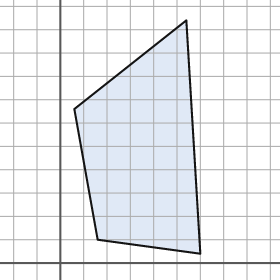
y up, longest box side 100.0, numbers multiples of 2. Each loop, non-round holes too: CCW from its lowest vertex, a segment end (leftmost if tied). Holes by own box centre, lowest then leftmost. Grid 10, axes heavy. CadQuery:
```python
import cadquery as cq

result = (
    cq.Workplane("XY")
    .moveTo(60.0, 4.0)
    .lineTo(54.0, 104.0)
    .lineTo(6.0, 66.0)
    .lineTo(16.0, 10.0)
    .close()
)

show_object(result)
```